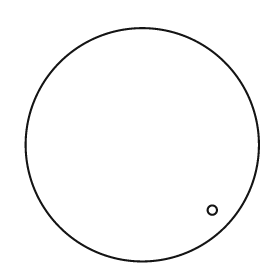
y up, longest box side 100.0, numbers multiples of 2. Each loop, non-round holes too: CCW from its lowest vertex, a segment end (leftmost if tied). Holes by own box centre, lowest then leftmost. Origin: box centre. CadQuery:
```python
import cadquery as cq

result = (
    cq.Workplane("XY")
    .moveTo(0.0, 0.0)
    .circle(50.0)
    .moveTo(30.0, -28.0)
    .circle(2.0)
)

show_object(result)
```